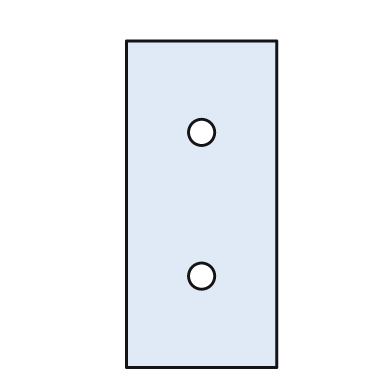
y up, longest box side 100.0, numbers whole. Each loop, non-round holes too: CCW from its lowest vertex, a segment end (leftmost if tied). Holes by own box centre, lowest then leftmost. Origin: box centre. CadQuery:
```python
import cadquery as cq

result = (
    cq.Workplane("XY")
    .moveTo(-23.0, -50.0)
    .lineTo(23.0, -50.0)
    .lineTo(23.0, 50.0)
    .lineTo(-23.0, 50.0)
    .close()
    .moveTo(0.0, -22.0)
    .circle(4.0)
    .moveTo(0.0, 22.0)
    .circle(4.0)
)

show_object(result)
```